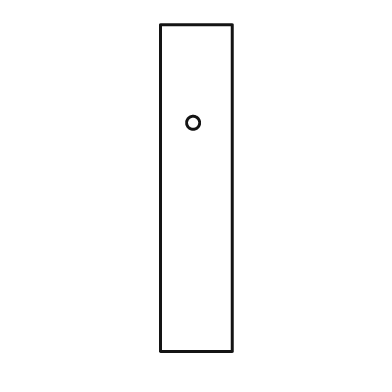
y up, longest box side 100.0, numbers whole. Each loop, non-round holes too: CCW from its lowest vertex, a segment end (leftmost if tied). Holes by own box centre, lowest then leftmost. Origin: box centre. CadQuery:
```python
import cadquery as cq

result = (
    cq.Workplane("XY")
    .moveTo(-11.0, -50.0)
    .lineTo(11.0, -50.0)
    .lineTo(11.0, 50.0)
    .lineTo(-11.0, 50.0)
    .close()
    .moveTo(-1.0, 20.0)
    .circle(2.0)
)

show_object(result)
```